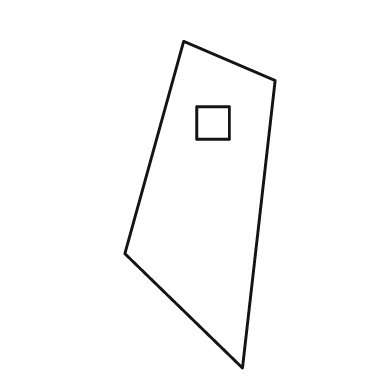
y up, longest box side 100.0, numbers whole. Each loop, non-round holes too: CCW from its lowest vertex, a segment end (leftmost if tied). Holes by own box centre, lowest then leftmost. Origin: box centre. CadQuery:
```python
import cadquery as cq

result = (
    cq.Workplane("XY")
    .moveTo(13.0, -50.0)
    .lineTo(23.0, 38.0)
    .lineTo(-5.0, 50.0)
    .lineTo(-23.0, -15.0)
    .close()
    .moveTo(-1.0, 20.0)
    .lineTo(9.0, 20.0)
    .lineTo(9.0, 30.0)
    .lineTo(-1.0, 30.0)
    .close()
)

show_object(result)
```